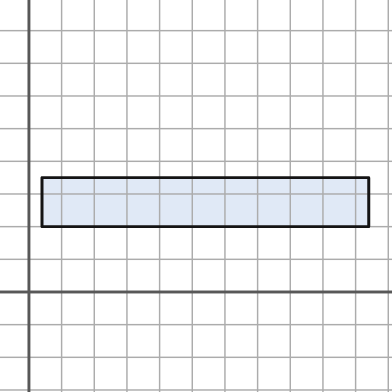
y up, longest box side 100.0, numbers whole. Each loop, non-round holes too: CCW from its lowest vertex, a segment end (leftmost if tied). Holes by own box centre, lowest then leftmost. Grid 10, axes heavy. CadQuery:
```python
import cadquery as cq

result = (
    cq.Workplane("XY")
    .moveTo(4.0, 20.0)
    .lineTo(104.0, 20.0)
    .lineTo(104.0, 35.0)
    .lineTo(4.0, 35.0)
    .close()
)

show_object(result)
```